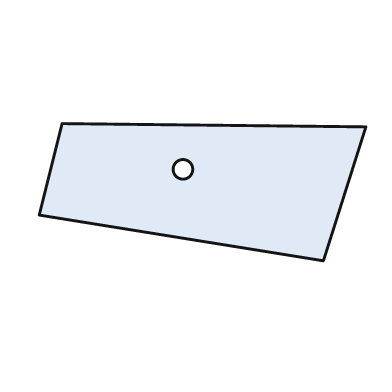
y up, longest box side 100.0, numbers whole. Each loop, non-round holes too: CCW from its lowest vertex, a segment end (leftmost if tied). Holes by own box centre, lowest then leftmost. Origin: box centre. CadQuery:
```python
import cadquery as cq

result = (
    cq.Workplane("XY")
    .moveTo(37.0, -21.0)
    .lineTo(50.0, 20.0)
    .lineTo(-43.0, 21.0)
    .lineTo(-50.0, -7.0)
    .close()
    .moveTo(-6.0, 7.0)
    .circle(3.0)
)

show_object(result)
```